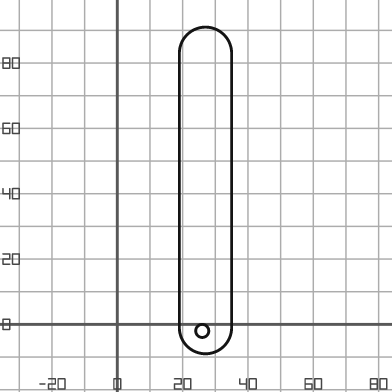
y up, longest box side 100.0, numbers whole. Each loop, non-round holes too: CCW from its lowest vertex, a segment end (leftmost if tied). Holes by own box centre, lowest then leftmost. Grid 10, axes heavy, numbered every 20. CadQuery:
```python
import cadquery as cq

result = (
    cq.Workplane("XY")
    .moveTo(19.0, -1.0)
    .threePointArc((27.0, -9.0), (35.0, -1.0))
    .lineTo(35.0, 83.0)
    .threePointArc((27.0, 91.0), (19.0, 83.0))
    .close()
    .moveTo(26.0, -2.0)
    .circle(2.0)
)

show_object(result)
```